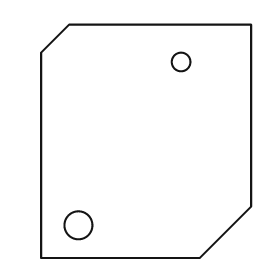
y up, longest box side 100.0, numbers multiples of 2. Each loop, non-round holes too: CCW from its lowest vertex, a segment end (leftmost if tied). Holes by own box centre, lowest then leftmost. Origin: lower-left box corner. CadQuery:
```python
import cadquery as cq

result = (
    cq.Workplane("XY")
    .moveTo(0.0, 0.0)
    .lineTo(68.0, 0.0)
    .lineTo(90.0, 22.0)
    .lineTo(90.0, 100.0)
    .lineTo(12.0, 100.0)
    .lineTo(0.0, 88.0)
    .close()
    .moveTo(16.0, 14.0)
    .circle(6.0)
    .moveTo(60.0, 84.0)
    .circle(4.0)
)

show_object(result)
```